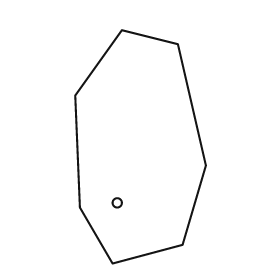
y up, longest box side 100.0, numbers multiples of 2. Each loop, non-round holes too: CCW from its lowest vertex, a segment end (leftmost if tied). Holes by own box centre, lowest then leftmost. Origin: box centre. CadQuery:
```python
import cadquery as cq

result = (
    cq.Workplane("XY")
    .moveTo(-12.0, -50.0)
    .lineTo(18.0, -42.0)
    .lineTo(28.0, -8.0)
    .lineTo(16.0, 44.0)
    .lineTo(-8.0, 50.0)
    .lineTo(-28.0, 22.0)
    .lineTo(-26.0, -26.0)
    .close()
    .moveTo(-10.0, -24.0)
    .circle(2.0)
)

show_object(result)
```